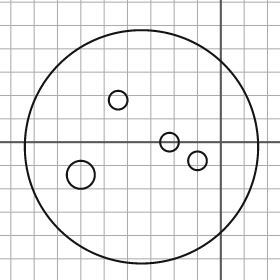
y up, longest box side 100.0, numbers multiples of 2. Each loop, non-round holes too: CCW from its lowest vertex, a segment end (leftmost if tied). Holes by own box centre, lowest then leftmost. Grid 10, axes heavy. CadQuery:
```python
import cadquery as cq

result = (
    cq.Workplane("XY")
    .moveTo(-34.0, -2.0)
    .circle(50.0)
    .moveTo(-60.0, -14.0)
    .circle(6.0)
    .moveTo(-10.0, -8.0)
    .circle(4.0)
    .moveTo(-22.0, 0.0)
    .circle(4.0)
    .moveTo(-44.0, 18.0)
    .circle(4.0)
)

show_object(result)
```